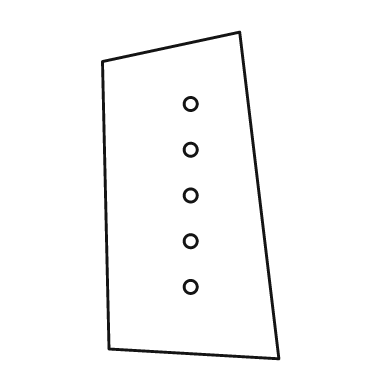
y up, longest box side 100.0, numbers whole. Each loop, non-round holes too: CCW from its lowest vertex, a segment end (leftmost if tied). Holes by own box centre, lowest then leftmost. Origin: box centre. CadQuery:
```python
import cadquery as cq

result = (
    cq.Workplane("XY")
    .moveTo(27.0, -50.0)
    .lineTo(15.0, 50.0)
    .lineTo(-27.0, 41.0)
    .lineTo(-25.0, -47.0)
    .close()
    .moveTo(0.0, -28.0)
    .circle(2.0)
    .moveTo(0.0, -14.0)
    .circle(2.0)
    .moveTo(0.0, 0.0)
    .circle(2.0)
    .moveTo(0.0, 14.0)
    .circle(2.0)
    .moveTo(0.0, 28.0)
    .circle(2.0)
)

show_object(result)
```